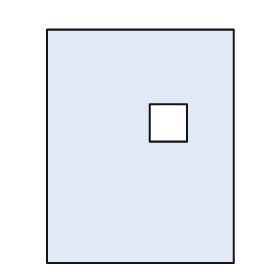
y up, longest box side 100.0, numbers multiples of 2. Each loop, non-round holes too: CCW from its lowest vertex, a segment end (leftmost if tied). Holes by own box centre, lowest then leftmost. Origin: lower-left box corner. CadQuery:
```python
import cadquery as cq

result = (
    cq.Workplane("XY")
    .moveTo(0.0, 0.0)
    .lineTo(80.0, 0.0)
    .lineTo(80.0, 100.0)
    .lineTo(0.0, 100.0)
    .close()
    .moveTo(44.0, 52.0)
    .lineTo(60.0, 52.0)
    .lineTo(60.0, 68.0)
    .lineTo(44.0, 68.0)
    .close()
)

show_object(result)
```